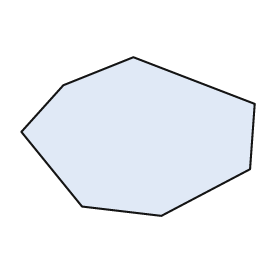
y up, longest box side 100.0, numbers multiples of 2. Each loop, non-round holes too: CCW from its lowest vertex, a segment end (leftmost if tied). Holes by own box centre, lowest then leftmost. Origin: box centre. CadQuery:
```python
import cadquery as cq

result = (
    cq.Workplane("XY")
    .moveTo(10.0, -34.0)
    .lineTo(48.0, -14.0)
    .lineTo(50.0, 14.0)
    .lineTo(-2.0, 34.0)
    .lineTo(-32.0, 22.0)
    .lineTo(-50.0, 2.0)
    .lineTo(-24.0, -30.0)
    .close()
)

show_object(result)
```